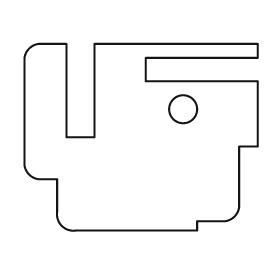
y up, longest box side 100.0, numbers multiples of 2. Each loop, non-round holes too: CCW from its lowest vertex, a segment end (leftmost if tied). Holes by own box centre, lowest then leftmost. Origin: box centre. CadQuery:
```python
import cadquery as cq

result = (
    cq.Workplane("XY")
    .moveTo(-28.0, -40.0)
    .lineTo(24.0, -40.0)
    .lineTo(24.0, -36.0)
    .lineTo(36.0, -36.0)
    .threePointArc((40.0, -34.0), (42.0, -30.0))
    .lineTo(42.0, -4.0)
    .lineTo(50.0, -4.0)
    .lineTo(50.0, 24.0)
    .lineTo(2.0, 24.0)
    .lineTo(2.0, 34.0)
    .lineTo(50.0, 34.0)
    .lineTo(50.0, 40.0)
    .lineTo(-20.0, 40.0)
    .lineTo(-20.0, 0.0)
    .lineTo(-32.0, 0.0)
    .lineTo(-32.0, 40.0)
    .lineTo(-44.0, 40.0)
    .threePointArc((-48.0, 38.0), (-50.0, 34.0))
    .lineTo(-50.0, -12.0)
    .threePointArc((-48.0, -16.0), (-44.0, -18.0))
    .lineTo(-36.0, -18.0)
    .lineTo(-36.0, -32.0)
    .threePointArc((-34.0, -38.0), (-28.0, -40.0))
    .close()
    .moveTo(18.0, 12.0)
    .circle(6.0)
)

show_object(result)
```